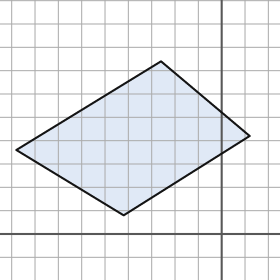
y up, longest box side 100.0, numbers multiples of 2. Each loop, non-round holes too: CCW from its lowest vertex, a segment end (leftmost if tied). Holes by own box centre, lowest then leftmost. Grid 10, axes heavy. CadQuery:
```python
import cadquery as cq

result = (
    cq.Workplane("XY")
    .moveTo(-42.0, 8.0)
    .lineTo(12.0, 42.0)
    .lineTo(-26.0, 74.0)
    .lineTo(-88.0, 36.0)
    .close()
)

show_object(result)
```